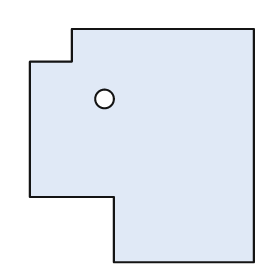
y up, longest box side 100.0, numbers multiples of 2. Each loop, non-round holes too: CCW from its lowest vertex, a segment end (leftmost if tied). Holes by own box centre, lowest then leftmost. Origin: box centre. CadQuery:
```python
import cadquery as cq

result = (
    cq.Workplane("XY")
    .moveTo(-12.0, -50.0)
    .lineTo(48.0, -50.0)
    .lineTo(48.0, 50.0)
    .lineTo(-30.0, 50.0)
    .lineTo(-30.0, 36.0)
    .lineTo(-48.0, 36.0)
    .lineTo(-48.0, -22.0)
    .lineTo(-12.0, -22.0)
    .close()
    .moveTo(-16.0, 20.0)
    .circle(4.0)
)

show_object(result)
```